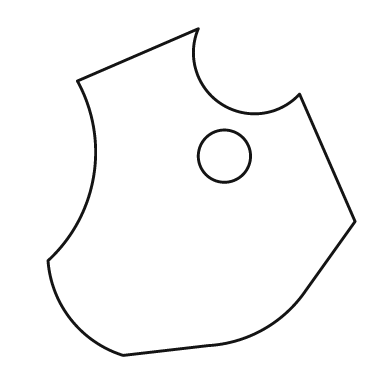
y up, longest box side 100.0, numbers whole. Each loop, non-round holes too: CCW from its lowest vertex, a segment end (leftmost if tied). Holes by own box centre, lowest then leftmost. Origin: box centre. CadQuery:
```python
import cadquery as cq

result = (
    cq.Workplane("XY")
    .moveTo(-24.0, -50.0)
    .lineTo(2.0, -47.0)
    .threePointArc((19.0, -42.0), (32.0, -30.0))
    .lineTo(47.0, -9.0)
    .lineTo(30.0, 30.0)
    .threePointArc((6.0, 27.0), (-1.0, 50.0))
    .lineTo(-38.0, 34.0)
    .threePointArc((-33.0, 5.0), (-47.0, -21.0))
    .threePointArc((-40.0, -39.0), (-24.0, -50.0))
    .close()
    .moveTo(7.0, 11.0)
    .circle(8.0)
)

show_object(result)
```